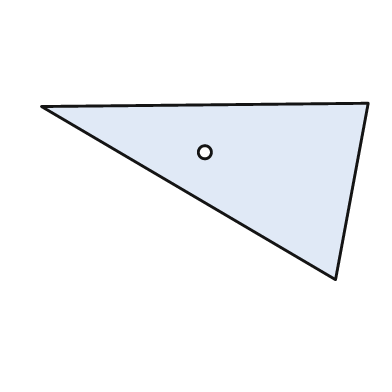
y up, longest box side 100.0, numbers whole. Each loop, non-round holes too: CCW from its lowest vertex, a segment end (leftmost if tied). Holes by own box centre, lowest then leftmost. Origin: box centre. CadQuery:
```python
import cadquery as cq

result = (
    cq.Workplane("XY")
    .moveTo(40.0, -27.0)
    .lineTo(50.0, 27.0)
    .lineTo(-50.0, 26.0)
    .close()
    .moveTo(0.0, 12.0)
    .circle(2.0)
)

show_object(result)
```